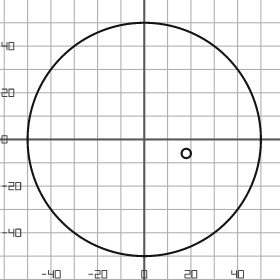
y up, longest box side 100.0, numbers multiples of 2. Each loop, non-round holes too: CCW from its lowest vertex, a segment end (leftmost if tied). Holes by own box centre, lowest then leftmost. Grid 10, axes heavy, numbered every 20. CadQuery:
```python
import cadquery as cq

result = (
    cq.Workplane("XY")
    .moveTo(0.0, 0.0)
    .circle(50.0)
    .moveTo(18.0, -6.0)
    .circle(2.0)
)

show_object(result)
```